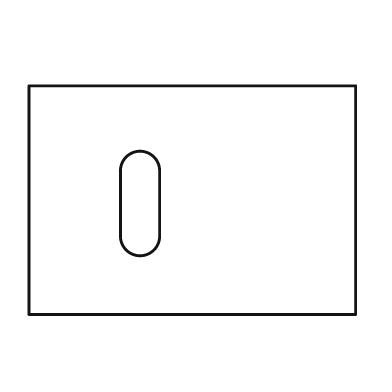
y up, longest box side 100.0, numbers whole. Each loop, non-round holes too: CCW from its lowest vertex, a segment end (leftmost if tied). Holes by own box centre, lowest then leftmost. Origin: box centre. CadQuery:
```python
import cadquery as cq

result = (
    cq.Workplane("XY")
    .moveTo(-50.0, -35.0)
    .lineTo(50.0, -35.0)
    .lineTo(50.0, 35.0)
    .lineTo(-50.0, 35.0)
    .close()
    .moveTo(-22.0, -11.0)
    .threePointArc((-16.0, -17.0), (-10.0, -11.0))
    .lineTo(-10.0, 9.0)
    .threePointArc((-16.0, 15.0), (-22.0, 9.0))
    .close()
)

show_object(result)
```